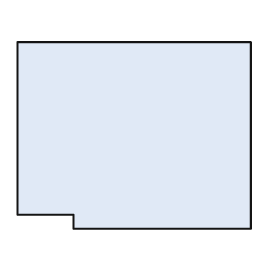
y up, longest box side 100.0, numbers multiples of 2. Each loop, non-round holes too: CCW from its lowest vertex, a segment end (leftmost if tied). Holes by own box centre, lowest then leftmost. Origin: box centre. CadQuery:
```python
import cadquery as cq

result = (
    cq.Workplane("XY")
    .moveTo(-26.0, -40.0)
    .lineTo(50.0, -40.0)
    .lineTo(50.0, 40.0)
    .lineTo(-50.0, 40.0)
    .lineTo(-50.0, -34.0)
    .lineTo(-26.0, -34.0)
    .close()
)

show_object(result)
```